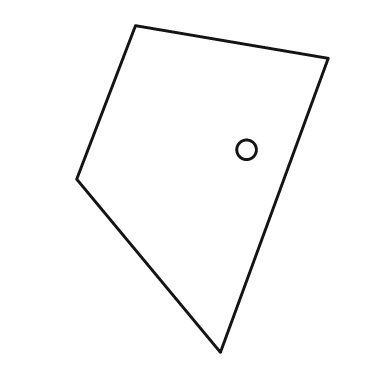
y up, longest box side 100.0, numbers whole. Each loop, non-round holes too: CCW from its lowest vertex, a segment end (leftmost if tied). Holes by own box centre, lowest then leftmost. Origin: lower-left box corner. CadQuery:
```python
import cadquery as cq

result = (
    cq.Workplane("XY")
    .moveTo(44.0, 0.0)
    .lineTo(77.0, 90.0)
    .lineTo(18.0, 100.0)
    .lineTo(0.0, 53.0)
    .close()
    .moveTo(52.0, 62.0)
    .circle(3.0)
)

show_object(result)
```